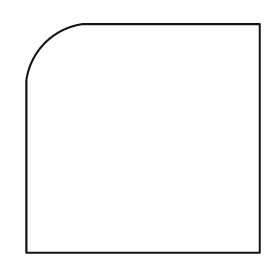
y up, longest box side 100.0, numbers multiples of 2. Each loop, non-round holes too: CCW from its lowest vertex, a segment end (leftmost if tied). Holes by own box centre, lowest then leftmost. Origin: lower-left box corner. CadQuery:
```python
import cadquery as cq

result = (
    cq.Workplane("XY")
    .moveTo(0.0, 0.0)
    .lineTo(100.0, 0.0)
    .lineTo(100.0, 98.0)
    .lineTo(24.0, 98.0)
    .threePointArc((8.0, 90.0), (0.0, 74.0))
    .close()
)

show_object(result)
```